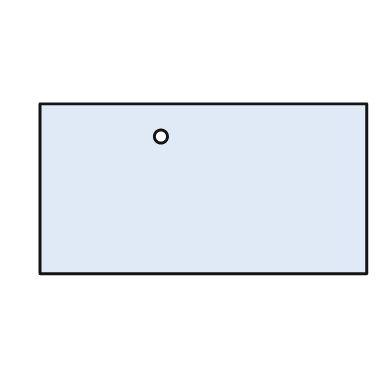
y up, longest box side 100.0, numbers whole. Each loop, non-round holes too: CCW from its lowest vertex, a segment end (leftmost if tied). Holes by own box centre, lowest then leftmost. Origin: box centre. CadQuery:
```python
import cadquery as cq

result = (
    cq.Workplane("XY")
    .moveTo(-50.0, -26.0)
    .lineTo(50.0, -26.0)
    .lineTo(50.0, 26.0)
    .lineTo(-50.0, 26.0)
    .close()
    .moveTo(-13.0, 16.0)
    .circle(2.0)
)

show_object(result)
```